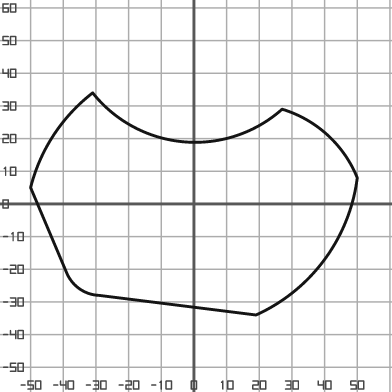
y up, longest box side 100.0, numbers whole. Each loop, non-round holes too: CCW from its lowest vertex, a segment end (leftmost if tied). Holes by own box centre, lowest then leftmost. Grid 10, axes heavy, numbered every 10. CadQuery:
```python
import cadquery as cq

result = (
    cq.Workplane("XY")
    .moveTo(19.0, -34.0)
    .threePointArc((40.0, -17.0), (50.0, 8.0))
    .threePointArc((41.0, 21.0), (27.0, 29.0))
    .threePointArc((-3.0, 19.0), (-31.0, 34.0))
    .threePointArc((-43.0, 21.0), (-50.0, 5.0))
    .lineTo(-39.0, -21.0)
    .threePointArc((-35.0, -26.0), (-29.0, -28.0))
    .close()
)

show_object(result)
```